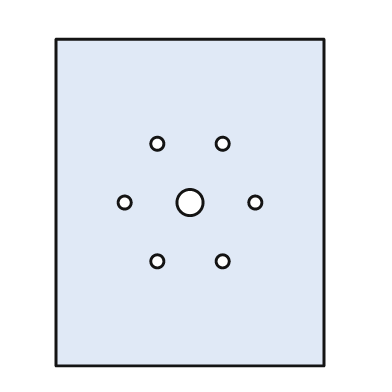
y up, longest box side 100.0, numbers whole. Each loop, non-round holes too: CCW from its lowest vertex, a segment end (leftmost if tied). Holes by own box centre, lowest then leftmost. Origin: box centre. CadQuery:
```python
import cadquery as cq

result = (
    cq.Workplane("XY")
    .moveTo(-41.0, -50.0)
    .lineTo(41.0, -50.0)
    .lineTo(41.0, 50.0)
    .lineTo(-41.0, 50.0)
    .close()
    .moveTo(-10.0, -18.0)
    .circle(2.0)
    .moveTo(10.0, -18.0)
    .circle(2.0)
    .moveTo(-20.0, 0.0)
    .circle(2.0)
    .moveTo(0.0, 0.0)
    .circle(4.0)
    .moveTo(20.0, 0.0)
    .circle(2.0)
    .moveTo(-10.0, 18.0)
    .circle(2.0)
    .moveTo(10.0, 18.0)
    .circle(2.0)
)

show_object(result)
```